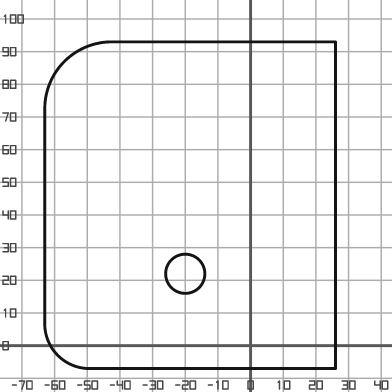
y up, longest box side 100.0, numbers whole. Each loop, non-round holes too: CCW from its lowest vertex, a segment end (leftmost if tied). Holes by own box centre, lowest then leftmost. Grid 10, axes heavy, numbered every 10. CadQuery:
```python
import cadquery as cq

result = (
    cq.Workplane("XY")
    .moveTo(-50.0, -7.0)
    .lineTo(26.0, -7.0)
    .lineTo(26.0, 93.0)
    .lineTo(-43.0, 93.0)
    .threePointArc((-57.0, 87.0), (-63.0, 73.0))
    .lineTo(-63.0, 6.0)
    .threePointArc((-59.0, -3.0), (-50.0, -7.0))
    .close()
    .moveTo(-20.0, 22.0)
    .circle(6.0)
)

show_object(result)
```